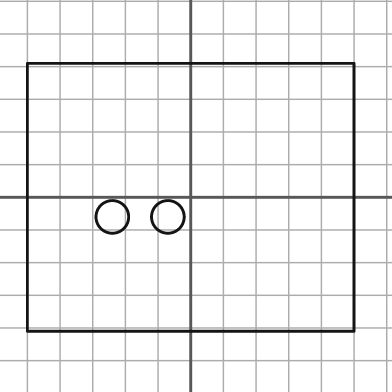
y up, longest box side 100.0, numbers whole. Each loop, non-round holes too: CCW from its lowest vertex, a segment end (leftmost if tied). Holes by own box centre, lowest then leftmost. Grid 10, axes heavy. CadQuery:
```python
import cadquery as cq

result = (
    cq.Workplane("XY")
    .moveTo(-50.0, -41.0)
    .lineTo(50.0, -41.0)
    .lineTo(50.0, 41.0)
    .lineTo(-50.0, 41.0)
    .close()
    .moveTo(-24.0, -6.0)
    .circle(5.0)
    .moveTo(-7.0, -6.0)
    .circle(5.0)
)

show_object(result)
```